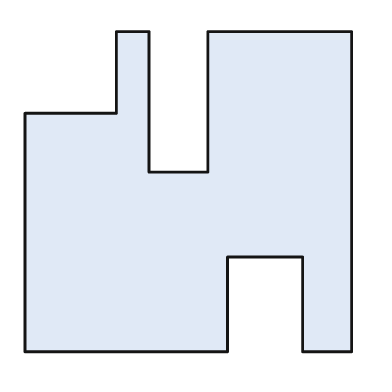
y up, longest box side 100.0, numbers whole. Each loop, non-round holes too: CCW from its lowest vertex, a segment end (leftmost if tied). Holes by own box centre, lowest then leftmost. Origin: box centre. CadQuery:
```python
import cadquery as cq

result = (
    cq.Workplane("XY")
    .moveTo(-50.0, -49.0)
    .lineTo(12.0, -49.0)
    .lineTo(12.0, -20.0)
    .lineTo(35.0, -20.0)
    .lineTo(35.0, -49.0)
    .lineTo(50.0, -49.0)
    .lineTo(50.0, 49.0)
    .lineTo(6.0, 49.0)
    .lineTo(6.0, 6.0)
    .lineTo(-12.0, 6.0)
    .lineTo(-12.0, 49.0)
    .lineTo(-22.0, 49.0)
    .lineTo(-22.0, 24.0)
    .lineTo(-50.0, 24.0)
    .close()
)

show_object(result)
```